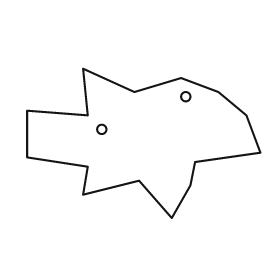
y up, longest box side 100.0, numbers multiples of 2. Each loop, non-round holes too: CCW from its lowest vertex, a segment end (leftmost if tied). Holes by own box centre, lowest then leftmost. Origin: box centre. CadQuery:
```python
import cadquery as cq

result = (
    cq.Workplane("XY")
    .moveTo(12.0, -32.0)
    .lineTo(20.0, -18.0)
    .lineTo(22.0, -8.0)
    .lineTo(50.0, -4.0)
    .lineTo(44.0, 12.0)
    .lineTo(32.0, 22.0)
    .lineTo(16.0, 28.0)
    .lineTo(-4.0, 22.0)
    .lineTo(-26.0, 32.0)
    .lineTo(-24.0, 12.0)
    .lineTo(-50.0, 14.0)
    .lineTo(-50.0, -6.0)
    .lineTo(-24.0, -10.0)
    .lineTo(-26.0, -22.0)
    .lineTo(-2.0, -16.0)
    .close()
    .moveTo(-18.0, 6.0)
    .circle(2.0)
    .moveTo(18.0, 20.0)
    .circle(2.0)
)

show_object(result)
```